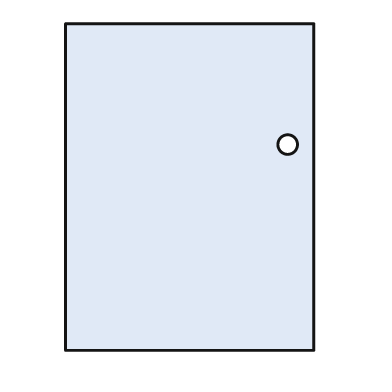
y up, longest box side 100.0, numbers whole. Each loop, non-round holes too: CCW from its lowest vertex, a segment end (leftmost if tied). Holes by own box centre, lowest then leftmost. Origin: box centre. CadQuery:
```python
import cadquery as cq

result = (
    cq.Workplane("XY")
    .moveTo(-38.0, -50.0)
    .lineTo(38.0, -50.0)
    .lineTo(38.0, 50.0)
    .lineTo(-38.0, 50.0)
    .close()
    .moveTo(30.0, 13.0)
    .circle(3.0)
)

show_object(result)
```